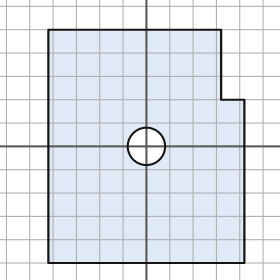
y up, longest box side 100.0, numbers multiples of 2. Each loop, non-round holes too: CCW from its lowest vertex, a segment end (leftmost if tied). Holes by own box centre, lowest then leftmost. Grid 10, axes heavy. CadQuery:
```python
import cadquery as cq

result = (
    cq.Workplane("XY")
    .moveTo(-42.0, -50.0)
    .lineTo(42.0, -50.0)
    .lineTo(42.0, 20.0)
    .lineTo(32.0, 20.0)
    .lineTo(32.0, 50.0)
    .lineTo(-42.0, 50.0)
    .close()
    .moveTo(0.0, 0.0)
    .circle(8.0)
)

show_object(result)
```